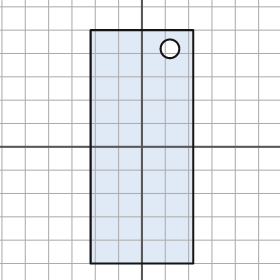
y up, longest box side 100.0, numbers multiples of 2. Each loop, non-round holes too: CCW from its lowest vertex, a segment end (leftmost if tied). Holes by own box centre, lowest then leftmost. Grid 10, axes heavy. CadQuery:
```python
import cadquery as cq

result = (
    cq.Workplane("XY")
    .moveTo(-22.0, -50.0)
    .lineTo(22.0, -50.0)
    .lineTo(22.0, 50.0)
    .lineTo(-22.0, 50.0)
    .close()
    .moveTo(12.0, 42.0)
    .circle(4.0)
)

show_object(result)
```